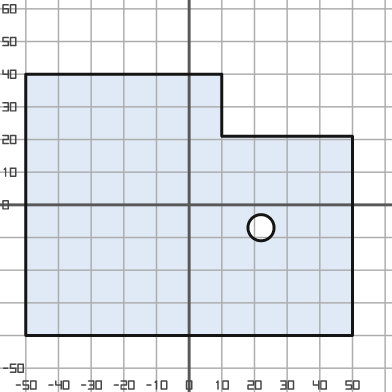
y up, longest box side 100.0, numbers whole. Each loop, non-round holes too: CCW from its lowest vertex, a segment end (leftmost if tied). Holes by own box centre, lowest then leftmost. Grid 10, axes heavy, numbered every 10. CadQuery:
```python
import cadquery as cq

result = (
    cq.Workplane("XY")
    .moveTo(-50.0, -40.0)
    .lineTo(50.0, -40.0)
    .lineTo(50.0, 21.0)
    .lineTo(10.0, 21.0)
    .lineTo(10.0, 40.0)
    .lineTo(-50.0, 40.0)
    .close()
    .moveTo(22.0, -7.0)
    .circle(4.0)
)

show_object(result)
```